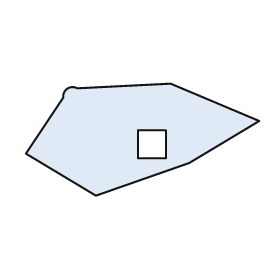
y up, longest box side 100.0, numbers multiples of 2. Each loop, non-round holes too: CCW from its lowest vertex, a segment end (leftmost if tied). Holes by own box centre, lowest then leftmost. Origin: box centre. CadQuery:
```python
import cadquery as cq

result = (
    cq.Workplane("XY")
    .moveTo(-20.0, -24.0)
    .lineTo(20.0, -10.0)
    .lineTo(50.0, 8.0)
    .lineTo(12.0, 24.0)
    .lineTo(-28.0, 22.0)
    .threePointArc((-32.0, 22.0), (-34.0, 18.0))
    .lineTo(-50.0, -6.0)
    .close()
    .moveTo(-2.0, -8.0)
    .lineTo(10.0, -8.0)
    .lineTo(10.0, 4.0)
    .lineTo(-2.0, 4.0)
    .close()
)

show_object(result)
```